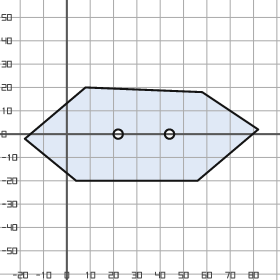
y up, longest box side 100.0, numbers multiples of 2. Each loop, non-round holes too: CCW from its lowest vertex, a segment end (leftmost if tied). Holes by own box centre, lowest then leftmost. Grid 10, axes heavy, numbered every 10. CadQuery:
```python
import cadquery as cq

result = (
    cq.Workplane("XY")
    .moveTo(4.0, -20.0)
    .lineTo(56.0, -20.0)
    .lineTo(82.0, 2.0)
    .lineTo(58.0, 18.0)
    .lineTo(8.0, 20.0)
    .lineTo(-18.0, -2.0)
    .close()
    .moveTo(22.0, 0.0)
    .circle(2.0)
    .moveTo(44.0, 0.0)
    .circle(2.0)
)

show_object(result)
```